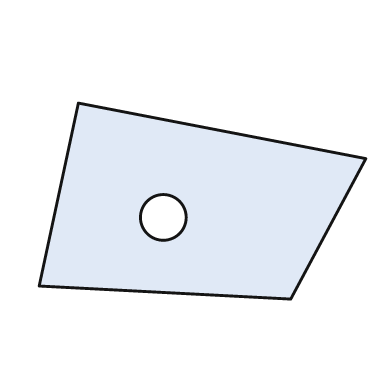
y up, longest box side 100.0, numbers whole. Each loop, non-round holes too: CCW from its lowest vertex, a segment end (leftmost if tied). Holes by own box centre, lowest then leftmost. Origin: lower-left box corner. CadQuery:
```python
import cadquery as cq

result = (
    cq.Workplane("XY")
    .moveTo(77.0, 0.0)
    .lineTo(100.0, 43.0)
    .lineTo(12.0, 60.0)
    .lineTo(0.0, 4.0)
    .close()
    .moveTo(38.0, 25.0)
    .circle(7.0)
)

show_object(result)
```